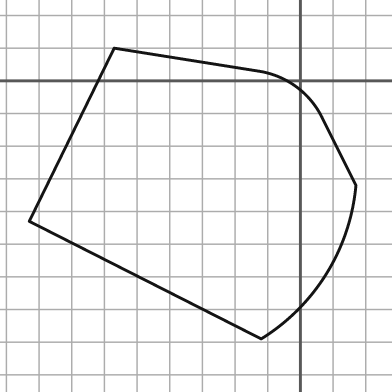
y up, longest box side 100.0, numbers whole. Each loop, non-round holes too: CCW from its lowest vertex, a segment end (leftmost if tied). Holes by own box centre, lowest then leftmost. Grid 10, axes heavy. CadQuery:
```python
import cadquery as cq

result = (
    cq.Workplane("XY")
    .moveTo(-12.0, -79.0)
    .threePointArc((8.0, -59.0), (17.0, -32.0))
    .lineTo(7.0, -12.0)
    .threePointArc((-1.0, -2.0), (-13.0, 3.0))
    .lineTo(-57.0, 10.0)
    .lineTo(-83.0, -43.0)
    .close()
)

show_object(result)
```